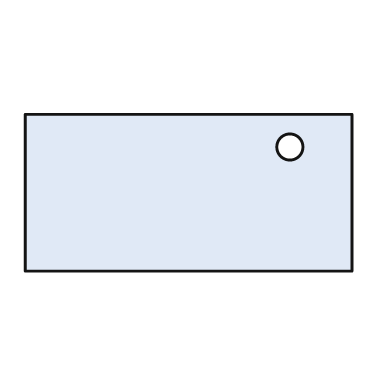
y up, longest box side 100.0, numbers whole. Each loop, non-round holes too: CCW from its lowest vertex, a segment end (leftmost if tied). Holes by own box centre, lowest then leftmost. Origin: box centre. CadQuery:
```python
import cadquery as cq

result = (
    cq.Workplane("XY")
    .moveTo(-50.0, -24.0)
    .lineTo(50.0, -24.0)
    .lineTo(50.0, 24.0)
    .lineTo(-50.0, 24.0)
    .close()
    .moveTo(31.0, 14.0)
    .circle(4.0)
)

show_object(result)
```